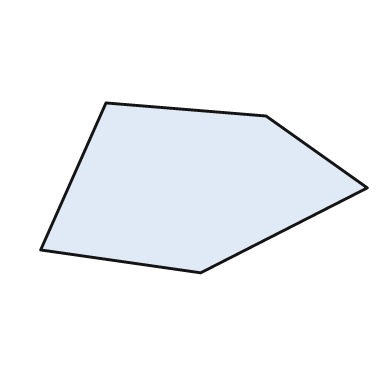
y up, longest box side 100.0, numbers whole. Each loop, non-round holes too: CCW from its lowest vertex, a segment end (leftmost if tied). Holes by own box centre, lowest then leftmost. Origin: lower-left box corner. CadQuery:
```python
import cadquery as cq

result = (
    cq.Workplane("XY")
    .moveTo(49.0, 0.0)
    .lineTo(100.0, 26.0)
    .lineTo(69.0, 48.0)
    .lineTo(20.0, 52.0)
    .lineTo(0.0, 7.0)
    .close()
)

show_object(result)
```